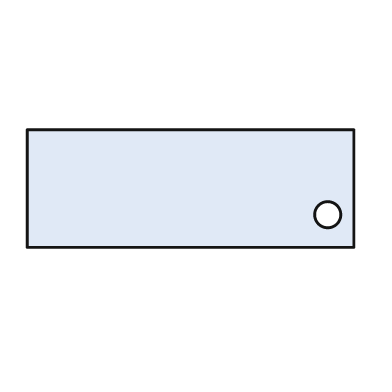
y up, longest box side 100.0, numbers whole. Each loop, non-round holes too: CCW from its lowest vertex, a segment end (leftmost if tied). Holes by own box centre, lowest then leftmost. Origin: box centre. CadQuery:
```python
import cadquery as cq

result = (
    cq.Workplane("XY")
    .moveTo(-50.0, -18.0)
    .lineTo(50.0, -18.0)
    .lineTo(50.0, 18.0)
    .lineTo(-50.0, 18.0)
    .close()
    .moveTo(42.0, -8.0)
    .circle(4.0)
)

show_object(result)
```